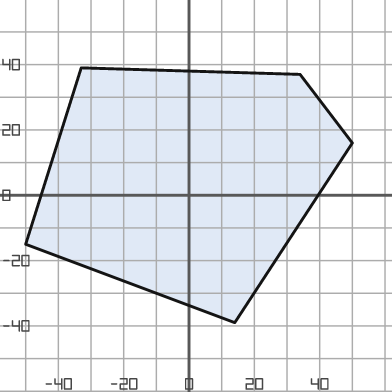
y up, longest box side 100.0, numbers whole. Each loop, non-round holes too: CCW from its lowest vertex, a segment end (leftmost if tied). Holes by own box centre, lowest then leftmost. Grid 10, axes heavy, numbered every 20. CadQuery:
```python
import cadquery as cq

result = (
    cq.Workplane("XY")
    .moveTo(14.0, -39.0)
    .lineTo(50.0, 16.0)
    .lineTo(34.0, 37.0)
    .lineTo(-33.0, 39.0)
    .lineTo(-50.0, -15.0)
    .close()
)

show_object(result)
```